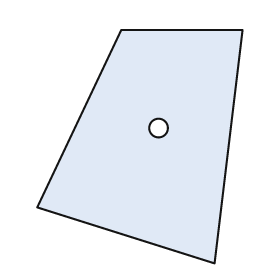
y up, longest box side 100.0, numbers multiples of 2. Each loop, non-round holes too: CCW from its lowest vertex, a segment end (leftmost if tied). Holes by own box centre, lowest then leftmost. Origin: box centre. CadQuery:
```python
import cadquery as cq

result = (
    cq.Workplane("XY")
    .moveTo(32.0, -50.0)
    .lineTo(44.0, 50.0)
    .lineTo(-8.0, 50.0)
    .lineTo(-44.0, -26.0)
    .close()
    .moveTo(8.0, 8.0)
    .circle(4.0)
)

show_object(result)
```